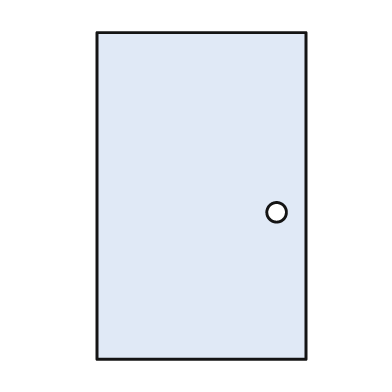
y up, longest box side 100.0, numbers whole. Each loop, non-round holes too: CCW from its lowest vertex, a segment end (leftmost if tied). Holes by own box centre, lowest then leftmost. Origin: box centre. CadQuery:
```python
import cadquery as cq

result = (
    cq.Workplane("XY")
    .moveTo(-32.0, -50.0)
    .lineTo(32.0, -50.0)
    .lineTo(32.0, 50.0)
    .lineTo(-32.0, 50.0)
    .close()
    .moveTo(23.0, -5.0)
    .circle(3.0)
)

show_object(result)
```